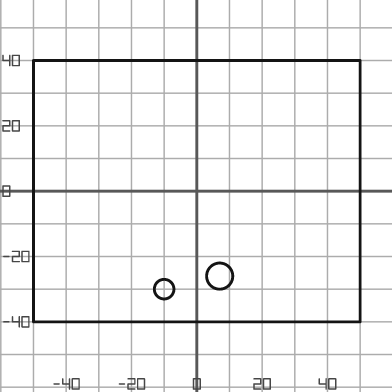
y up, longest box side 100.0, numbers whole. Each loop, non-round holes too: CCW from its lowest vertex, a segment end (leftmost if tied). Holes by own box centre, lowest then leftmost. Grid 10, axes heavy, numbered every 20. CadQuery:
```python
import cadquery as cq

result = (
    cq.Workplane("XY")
    .moveTo(-50.0, -40.0)
    .lineTo(50.0, -40.0)
    .lineTo(50.0, 40.0)
    .lineTo(-50.0, 40.0)
    .close()
    .moveTo(-10.0, -30.0)
    .circle(3.0)
    .moveTo(7.0, -26.0)
    .circle(4.0)
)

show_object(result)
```